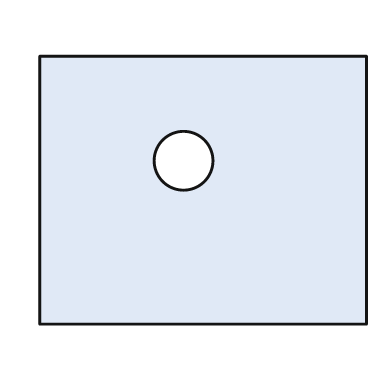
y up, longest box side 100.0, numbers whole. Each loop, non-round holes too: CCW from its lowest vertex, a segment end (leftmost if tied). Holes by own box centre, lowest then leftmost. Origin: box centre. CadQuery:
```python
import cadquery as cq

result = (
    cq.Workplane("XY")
    .moveTo(-50.0, -41.0)
    .lineTo(50.0, -41.0)
    .lineTo(50.0, 41.0)
    .lineTo(-50.0, 41.0)
    .close()
    .moveTo(-6.0, 9.0)
    .circle(9.0)
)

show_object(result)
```